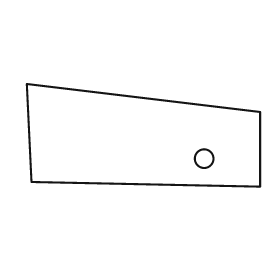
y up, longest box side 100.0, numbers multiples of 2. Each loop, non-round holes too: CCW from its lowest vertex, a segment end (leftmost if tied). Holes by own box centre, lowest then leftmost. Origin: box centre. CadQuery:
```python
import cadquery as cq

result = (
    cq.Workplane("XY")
    .moveTo(50.0, -22.0)
    .lineTo(50.0, 10.0)
    .lineTo(-50.0, 22.0)
    .lineTo(-48.0, -20.0)
    .close()
    .moveTo(26.0, -10.0)
    .circle(4.0)
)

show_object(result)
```